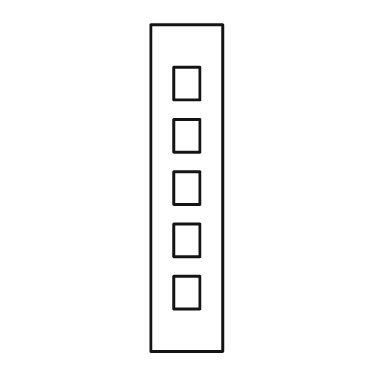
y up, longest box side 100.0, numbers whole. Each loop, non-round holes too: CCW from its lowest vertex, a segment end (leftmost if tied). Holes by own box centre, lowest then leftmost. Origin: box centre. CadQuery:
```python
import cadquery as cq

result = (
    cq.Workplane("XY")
    .moveTo(-11.0, -50.0)
    .lineTo(11.0, -50.0)
    .lineTo(11.0, 50.0)
    .lineTo(-11.0, 50.0)
    .close()
    .moveTo(-4.0, -37.0)
    .lineTo(4.0, -37.0)
    .lineTo(4.0, -27.0)
    .lineTo(-4.0, -27.0)
    .close()
    .moveTo(-4.0, -21.0)
    .lineTo(4.0, -21.0)
    .lineTo(4.0, -11.0)
    .lineTo(-4.0, -11.0)
    .close()
    .moveTo(-4.0, -5.0)
    .lineTo(4.0, -5.0)
    .lineTo(4.0, 5.0)
    .lineTo(-4.0, 5.0)
    .close()
    .moveTo(-4.0, 11.0)
    .lineTo(4.0, 11.0)
    .lineTo(4.0, 21.0)
    .lineTo(-4.0, 21.0)
    .close()
    .moveTo(-4.0, 27.0)
    .lineTo(4.0, 27.0)
    .lineTo(4.0, 37.0)
    .lineTo(-4.0, 37.0)
    .close()
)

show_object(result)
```